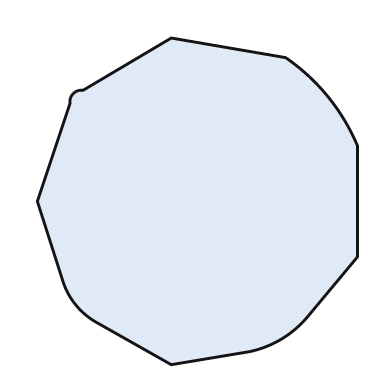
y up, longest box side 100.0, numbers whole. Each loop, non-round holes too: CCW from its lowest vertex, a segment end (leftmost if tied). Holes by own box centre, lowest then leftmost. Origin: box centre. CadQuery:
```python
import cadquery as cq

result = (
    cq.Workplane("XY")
    .moveTo(-8.0, -50.0)
    .lineTo(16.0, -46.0)
    .threePointArc((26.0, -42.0), (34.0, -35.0))
    .lineTo(49.0, -17.0)
    .lineTo(49.0, 17.0)
    .threePointArc((40.0, 32.0), (27.0, 44.0))
    .lineTo(-8.0, 50.0)
    .lineTo(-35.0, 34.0)
    .threePointArc((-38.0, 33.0), (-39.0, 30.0))
    .lineTo(-49.0, 0.0)
    .lineTo(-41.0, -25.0)
    .threePointArc((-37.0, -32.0), (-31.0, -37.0))
    .close()
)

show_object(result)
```